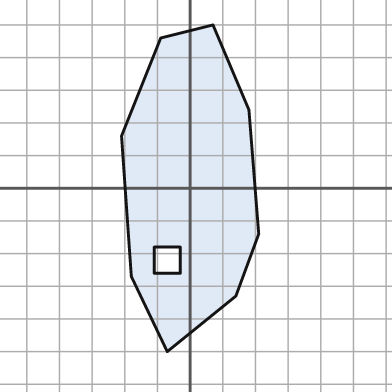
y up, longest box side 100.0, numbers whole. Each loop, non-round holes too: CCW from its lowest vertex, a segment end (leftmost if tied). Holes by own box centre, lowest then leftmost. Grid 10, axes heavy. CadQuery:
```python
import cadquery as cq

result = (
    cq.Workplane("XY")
    .moveTo(-7.0, -50.0)
    .lineTo(14.0, -33.0)
    .lineTo(21.0, -14.0)
    .lineTo(18.0, 24.0)
    .lineTo(7.0, 50.0)
    .lineTo(-9.0, 46.0)
    .lineTo(-21.0, 16.0)
    .lineTo(-18.0, -27.0)
    .close()
    .moveTo(-11.0, -26.0)
    .lineTo(-3.0, -26.0)
    .lineTo(-3.0, -18.0)
    .lineTo(-11.0, -18.0)
    .close()
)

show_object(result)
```